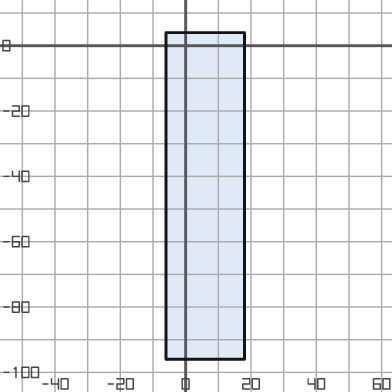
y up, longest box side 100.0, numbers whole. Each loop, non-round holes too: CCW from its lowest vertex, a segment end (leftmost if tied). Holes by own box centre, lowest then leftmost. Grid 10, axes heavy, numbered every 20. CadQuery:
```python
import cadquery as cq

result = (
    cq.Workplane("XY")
    .moveTo(-6.0, -96.0)
    .lineTo(18.0, -96.0)
    .lineTo(18.0, 4.0)
    .lineTo(-6.0, 4.0)
    .close()
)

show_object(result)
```